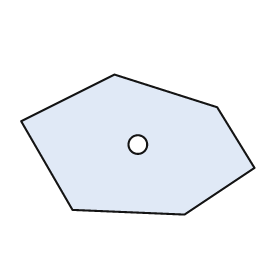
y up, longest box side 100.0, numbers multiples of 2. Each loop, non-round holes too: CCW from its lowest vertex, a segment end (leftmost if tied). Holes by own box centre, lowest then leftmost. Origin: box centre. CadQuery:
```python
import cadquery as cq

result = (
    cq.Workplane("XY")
    .moveTo(20.0, -30.0)
    .lineTo(50.0, -10.0)
    .lineTo(34.0, 16.0)
    .lineTo(-10.0, 30.0)
    .lineTo(-50.0, 10.0)
    .lineTo(-28.0, -28.0)
    .close()
    .moveTo(0.0, 0.0)
    .circle(4.0)
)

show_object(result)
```